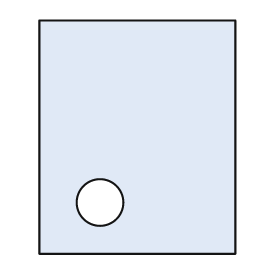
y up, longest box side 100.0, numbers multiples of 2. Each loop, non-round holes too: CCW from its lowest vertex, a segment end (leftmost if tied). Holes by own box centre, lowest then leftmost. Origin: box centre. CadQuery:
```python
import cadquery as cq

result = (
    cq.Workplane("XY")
    .moveTo(-42.0, -50.0)
    .lineTo(42.0, -50.0)
    .lineTo(42.0, 50.0)
    .lineTo(-42.0, 50.0)
    .close()
    .moveTo(-16.0, -28.0)
    .circle(10.0)
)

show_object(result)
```